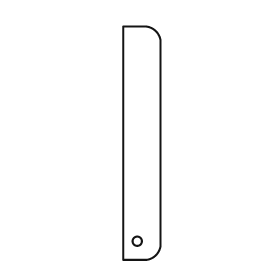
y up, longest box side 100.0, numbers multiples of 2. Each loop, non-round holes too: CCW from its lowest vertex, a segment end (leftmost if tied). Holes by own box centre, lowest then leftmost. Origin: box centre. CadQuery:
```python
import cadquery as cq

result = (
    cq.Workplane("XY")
    .moveTo(-8.0, -50.0)
    .lineTo(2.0, -50.0)
    .threePointArc((6.0, -48.0), (8.0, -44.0))
    .lineTo(8.0, 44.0)
    .threePointArc((6.0, 48.0), (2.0, 50.0))
    .lineTo(-8.0, 50.0)
    .close()
    .moveTo(-2.0, -42.0)
    .circle(2.0)
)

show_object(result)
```